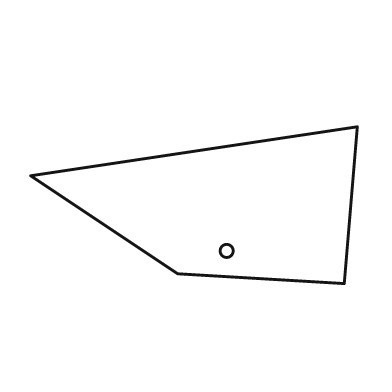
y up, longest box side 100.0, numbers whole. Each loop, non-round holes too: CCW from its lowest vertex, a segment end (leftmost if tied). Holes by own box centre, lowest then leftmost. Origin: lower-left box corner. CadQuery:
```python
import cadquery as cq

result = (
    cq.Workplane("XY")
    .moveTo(96.0, 0.0)
    .lineTo(100.0, 48.0)
    .lineTo(0.0, 33.0)
    .lineTo(45.0, 3.0)
    .close()
    .moveTo(60.0, 10.0)
    .circle(2.0)
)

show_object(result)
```